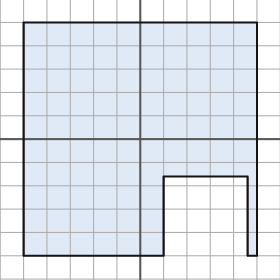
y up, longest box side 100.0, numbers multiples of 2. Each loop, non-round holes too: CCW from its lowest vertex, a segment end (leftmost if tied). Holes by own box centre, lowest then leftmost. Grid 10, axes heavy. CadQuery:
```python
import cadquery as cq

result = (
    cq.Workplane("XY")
    .moveTo(-50.0, -50.0)
    .lineTo(10.0, -50.0)
    .lineTo(10.0, -16.0)
    .lineTo(46.0, -16.0)
    .lineTo(46.0, -50.0)
    .lineTo(50.0, -50.0)
    .lineTo(50.0, 50.0)
    .lineTo(-50.0, 50.0)
    .close()
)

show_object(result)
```